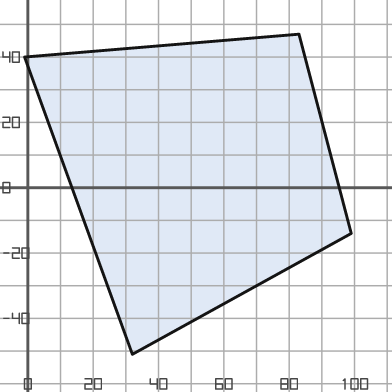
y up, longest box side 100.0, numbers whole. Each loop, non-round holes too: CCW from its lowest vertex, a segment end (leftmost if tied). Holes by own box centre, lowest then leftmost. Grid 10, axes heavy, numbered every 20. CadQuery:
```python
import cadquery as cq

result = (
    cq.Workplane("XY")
    .moveTo(32.0, -51.0)
    .lineTo(99.0, -14.0)
    .lineTo(83.0, 47.0)
    .lineTo(-1.0, 40.0)
    .close()
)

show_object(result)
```